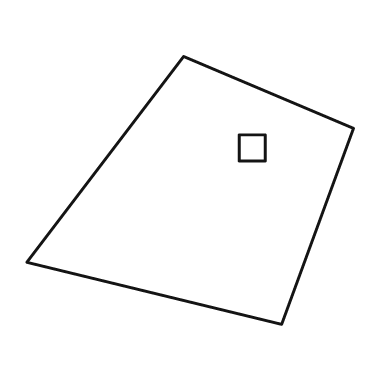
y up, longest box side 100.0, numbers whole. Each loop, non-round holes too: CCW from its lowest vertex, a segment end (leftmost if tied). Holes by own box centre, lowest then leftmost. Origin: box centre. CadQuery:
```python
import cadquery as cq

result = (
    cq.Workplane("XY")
    .moveTo(28.0, -41.0)
    .lineTo(50.0, 19.0)
    .lineTo(-2.0, 41.0)
    .lineTo(-50.0, -22.0)
    .close()
    .moveTo(15.0, 9.0)
    .lineTo(23.0, 9.0)
    .lineTo(23.0, 17.0)
    .lineTo(15.0, 17.0)
    .close()
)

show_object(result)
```